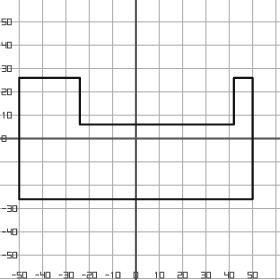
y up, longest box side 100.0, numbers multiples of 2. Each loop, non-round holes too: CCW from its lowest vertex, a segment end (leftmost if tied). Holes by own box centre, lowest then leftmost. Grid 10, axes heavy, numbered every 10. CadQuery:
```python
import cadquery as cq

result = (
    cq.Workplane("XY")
    .moveTo(-50.0, -26.0)
    .lineTo(50.0, -26.0)
    .lineTo(50.0, 26.0)
    .lineTo(42.0, 26.0)
    .lineTo(42.0, 6.0)
    .lineTo(-24.0, 6.0)
    .lineTo(-24.0, 26.0)
    .lineTo(-50.0, 26.0)
    .close()
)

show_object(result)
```